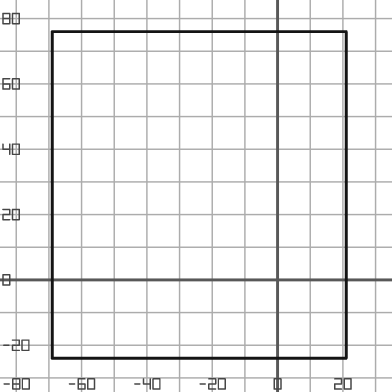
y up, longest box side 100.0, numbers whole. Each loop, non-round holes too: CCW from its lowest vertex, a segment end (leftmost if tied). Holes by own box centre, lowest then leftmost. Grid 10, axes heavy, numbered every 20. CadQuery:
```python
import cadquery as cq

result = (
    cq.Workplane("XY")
    .moveTo(-69.0, -24.0)
    .lineTo(21.0, -24.0)
    .lineTo(21.0, 76.0)
    .lineTo(-69.0, 76.0)
    .close()
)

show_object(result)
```